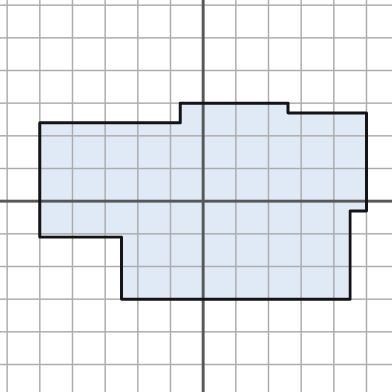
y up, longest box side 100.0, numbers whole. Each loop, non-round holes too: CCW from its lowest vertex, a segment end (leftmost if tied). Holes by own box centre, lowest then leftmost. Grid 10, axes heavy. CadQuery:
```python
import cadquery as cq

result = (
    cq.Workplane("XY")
    .moveTo(-25.0, -30.0)
    .lineTo(45.0, -30.0)
    .lineTo(45.0, -3.0)
    .lineTo(50.0, -3.0)
    .lineTo(50.0, 27.0)
    .lineTo(26.0, 27.0)
    .lineTo(26.0, 30.0)
    .lineTo(-7.0, 30.0)
    .lineTo(-7.0, 24.0)
    .lineTo(-50.0, 24.0)
    .lineTo(-50.0, -11.0)
    .lineTo(-25.0, -11.0)
    .close()
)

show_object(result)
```